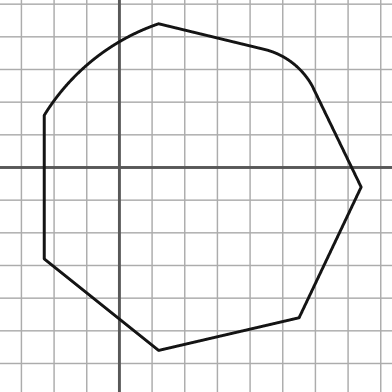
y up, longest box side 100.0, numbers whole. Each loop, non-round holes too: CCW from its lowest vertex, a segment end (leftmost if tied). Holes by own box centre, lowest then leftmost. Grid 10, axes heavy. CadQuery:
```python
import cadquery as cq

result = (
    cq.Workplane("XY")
    .moveTo(12.0, -56.0)
    .lineTo(55.0, -46.0)
    .lineTo(74.0, -6.0)
    .lineTo(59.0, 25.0)
    .threePointArc((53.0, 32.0), (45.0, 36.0))
    .lineTo(12.0, 44.0)
    .threePointArc((-8.0, 33.0), (-23.0, 16.0))
    .lineTo(-23.0, -28.0)
    .close()
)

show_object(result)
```